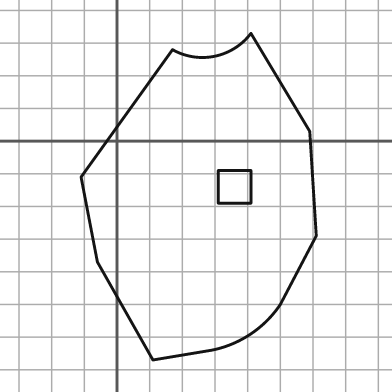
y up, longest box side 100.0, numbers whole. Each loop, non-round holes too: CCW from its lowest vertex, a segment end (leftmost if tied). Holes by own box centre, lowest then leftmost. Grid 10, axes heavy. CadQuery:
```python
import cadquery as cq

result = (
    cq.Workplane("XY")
    .moveTo(11.0, -67.0)
    .lineTo(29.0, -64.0)
    .threePointArc((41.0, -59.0), (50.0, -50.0))
    .lineTo(61.0, -29.0)
    .lineTo(59.0, 3.0)
    .lineTo(41.0, 33.0)
    .threePointArc((30.0, 26.0), (17.0, 28.0))
    .lineTo(-11.0, -11.0)
    .lineTo(-6.0, -37.0)
    .close()
    .moveTo(31.0, -19.0)
    .lineTo(41.0, -19.0)
    .lineTo(41.0, -9.0)
    .lineTo(31.0, -9.0)
    .close()
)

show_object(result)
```